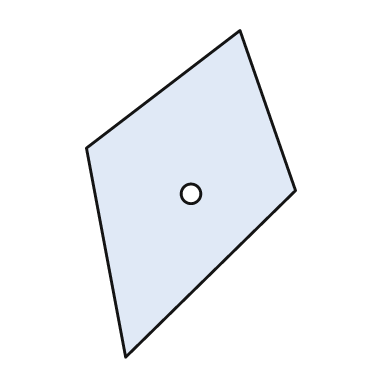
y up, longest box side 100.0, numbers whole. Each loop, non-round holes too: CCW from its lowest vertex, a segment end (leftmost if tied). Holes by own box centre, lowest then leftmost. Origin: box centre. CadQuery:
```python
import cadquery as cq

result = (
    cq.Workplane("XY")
    .moveTo(-20.0, -50.0)
    .lineTo(32.0, 1.0)
    .lineTo(15.0, 50.0)
    .lineTo(-32.0, 14.0)
    .close()
    .moveTo(0.0, 0.0)
    .circle(3.0)
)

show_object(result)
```